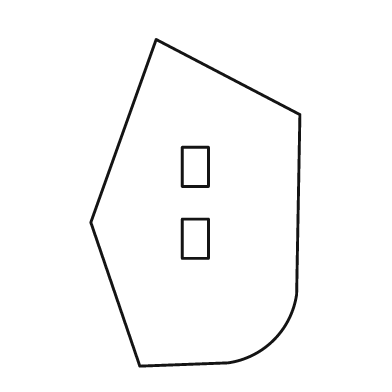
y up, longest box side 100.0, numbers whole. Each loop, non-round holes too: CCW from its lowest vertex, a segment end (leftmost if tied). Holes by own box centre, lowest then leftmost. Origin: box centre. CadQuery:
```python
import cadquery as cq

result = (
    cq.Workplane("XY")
    .moveTo(-17.0, -50.0)
    .lineTo(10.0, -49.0)
    .threePointArc((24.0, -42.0), (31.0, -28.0))
    .lineTo(32.0, 27.0)
    .lineTo(-12.0, 50.0)
    .lineTo(-32.0, -6.0)
    .close()
    .moveTo(-4.0, -17.0)
    .lineTo(4.0, -17.0)
    .lineTo(4.0, -5.0)
    .lineTo(-4.0, -5.0)
    .close()
    .moveTo(-4.0, 5.0)
    .lineTo(4.0, 5.0)
    .lineTo(4.0, 17.0)
    .lineTo(-4.0, 17.0)
    .close()
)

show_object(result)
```